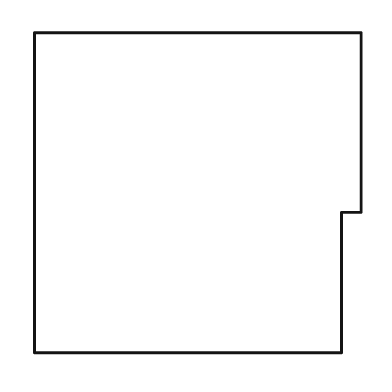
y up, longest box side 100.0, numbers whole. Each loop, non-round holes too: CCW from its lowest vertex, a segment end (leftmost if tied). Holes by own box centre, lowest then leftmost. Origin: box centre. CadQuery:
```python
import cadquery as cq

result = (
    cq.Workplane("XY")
    .moveTo(-50.0, -49.0)
    .lineTo(44.0, -49.0)
    .lineTo(44.0, -6.0)
    .lineTo(50.0, -6.0)
    .lineTo(50.0, 49.0)
    .lineTo(-50.0, 49.0)
    .close()
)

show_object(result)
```